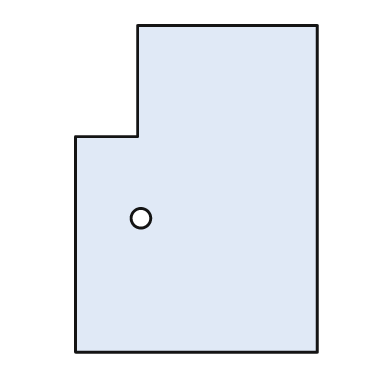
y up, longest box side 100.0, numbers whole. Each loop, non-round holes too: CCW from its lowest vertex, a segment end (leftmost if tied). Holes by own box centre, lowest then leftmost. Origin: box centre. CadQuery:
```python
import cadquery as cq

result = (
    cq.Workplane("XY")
    .moveTo(-37.0, -50.0)
    .lineTo(37.0, -50.0)
    .lineTo(37.0, 50.0)
    .lineTo(-18.0, 50.0)
    .lineTo(-18.0, 16.0)
    .lineTo(-37.0, 16.0)
    .close()
    .moveTo(-17.0, -9.0)
    .circle(3.0)
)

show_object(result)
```